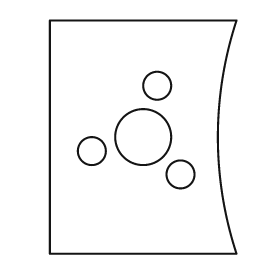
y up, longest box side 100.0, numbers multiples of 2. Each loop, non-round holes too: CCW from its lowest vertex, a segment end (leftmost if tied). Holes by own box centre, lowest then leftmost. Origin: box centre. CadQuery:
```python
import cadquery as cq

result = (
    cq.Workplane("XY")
    .moveTo(-40.0, -50.0)
    .lineTo(40.0, -50.0)
    .threePointArc((32.0, 0.0), (40.0, 50.0))
    .lineTo(-40.0, 50.0)
    .close()
    .moveTo(16.0, -16.0)
    .circle(6.0)
    .moveTo(-22.0, -6.0)
    .circle(6.0)
    .moveTo(0.0, 0.0)
    .circle(12.0)
    .moveTo(6.0, 22.0)
    .circle(6.0)
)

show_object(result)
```